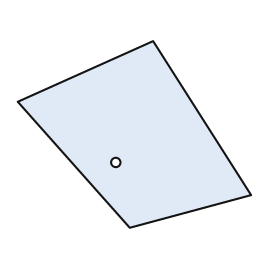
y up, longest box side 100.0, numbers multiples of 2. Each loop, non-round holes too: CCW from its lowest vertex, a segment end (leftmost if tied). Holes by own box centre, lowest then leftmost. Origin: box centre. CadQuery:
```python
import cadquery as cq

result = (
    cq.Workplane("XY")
    .moveTo(-2.0, -40.0)
    .lineTo(50.0, -26.0)
    .lineTo(8.0, 40.0)
    .lineTo(-50.0, 14.0)
    .close()
    .moveTo(-8.0, -12.0)
    .circle(2.0)
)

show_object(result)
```